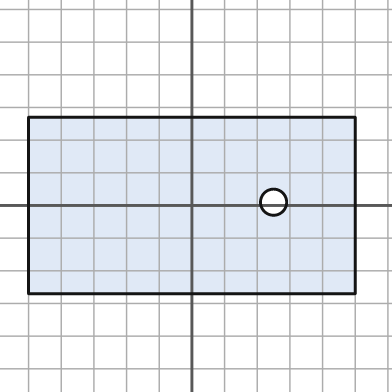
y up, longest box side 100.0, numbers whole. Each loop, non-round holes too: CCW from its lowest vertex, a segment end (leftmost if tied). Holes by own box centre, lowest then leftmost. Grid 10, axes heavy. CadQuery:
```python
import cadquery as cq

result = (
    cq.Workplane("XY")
    .moveTo(-50.0, -27.0)
    .lineTo(50.0, -27.0)
    .lineTo(50.0, 27.0)
    .lineTo(-50.0, 27.0)
    .close()
    .moveTo(25.0, 1.0)
    .circle(4.0)
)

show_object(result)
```